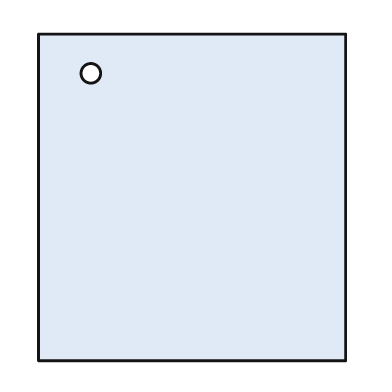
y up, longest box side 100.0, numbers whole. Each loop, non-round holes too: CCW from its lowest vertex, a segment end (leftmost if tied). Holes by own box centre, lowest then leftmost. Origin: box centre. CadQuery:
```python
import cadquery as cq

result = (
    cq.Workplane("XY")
    .moveTo(-47.0, -50.0)
    .lineTo(47.0, -50.0)
    .lineTo(47.0, 50.0)
    .lineTo(-47.0, 50.0)
    .close()
    .moveTo(-31.0, 38.0)
    .circle(3.0)
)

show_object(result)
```